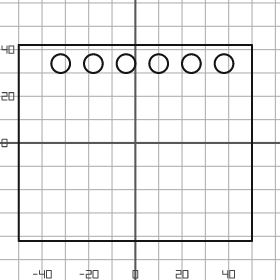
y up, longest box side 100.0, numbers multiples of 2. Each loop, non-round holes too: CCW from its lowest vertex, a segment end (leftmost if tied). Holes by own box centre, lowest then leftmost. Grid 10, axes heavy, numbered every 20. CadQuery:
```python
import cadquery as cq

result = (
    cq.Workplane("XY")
    .moveTo(-50.0, -42.0)
    .lineTo(50.0, -42.0)
    .lineTo(50.0, 42.0)
    .lineTo(-50.0, 42.0)
    .close()
    .moveTo(-32.0, 34.0)
    .circle(4.0)
    .moveTo(-18.0, 34.0)
    .circle(4.0)
    .moveTo(-4.0, 34.0)
    .circle(4.0)
    .moveTo(10.0, 34.0)
    .circle(4.0)
    .moveTo(24.0, 34.0)
    .circle(4.0)
    .moveTo(38.0, 34.0)
    .circle(4.0)
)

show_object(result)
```